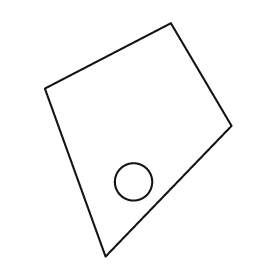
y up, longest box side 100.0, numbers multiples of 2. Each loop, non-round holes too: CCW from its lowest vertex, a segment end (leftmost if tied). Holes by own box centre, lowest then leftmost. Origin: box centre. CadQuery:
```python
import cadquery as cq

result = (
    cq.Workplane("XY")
    .moveTo(-14.0, -50.0)
    .lineTo(40.0, 6.0)
    .lineTo(14.0, 50.0)
    .lineTo(-40.0, 22.0)
    .close()
    .moveTo(-2.0, -18.0)
    .circle(8.0)
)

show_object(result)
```